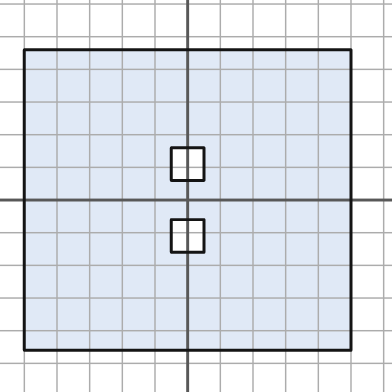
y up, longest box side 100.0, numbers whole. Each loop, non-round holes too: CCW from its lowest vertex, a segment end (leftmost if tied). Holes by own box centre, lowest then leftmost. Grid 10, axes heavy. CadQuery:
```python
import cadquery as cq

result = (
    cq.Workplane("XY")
    .moveTo(-50.0, -46.0)
    .lineTo(50.0, -46.0)
    .lineTo(50.0, 46.0)
    .lineTo(-50.0, 46.0)
    .close()
    .moveTo(-5.0, -16.0)
    .lineTo(5.0, -16.0)
    .lineTo(5.0, -6.0)
    .lineTo(-5.0, -6.0)
    .close()
    .moveTo(-5.0, 6.0)
    .lineTo(5.0, 6.0)
    .lineTo(5.0, 16.0)
    .lineTo(-5.0, 16.0)
    .close()
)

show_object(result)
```